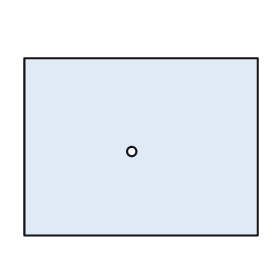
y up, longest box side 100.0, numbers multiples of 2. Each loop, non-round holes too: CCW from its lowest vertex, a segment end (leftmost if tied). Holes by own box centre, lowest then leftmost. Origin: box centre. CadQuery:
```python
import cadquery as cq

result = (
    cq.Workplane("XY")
    .moveTo(-50.0, -38.0)
    .lineTo(50.0, -38.0)
    .lineTo(50.0, 38.0)
    .lineTo(-50.0, 38.0)
    .close()
    .moveTo(-4.0, -2.0)
    .circle(2.0)
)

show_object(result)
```